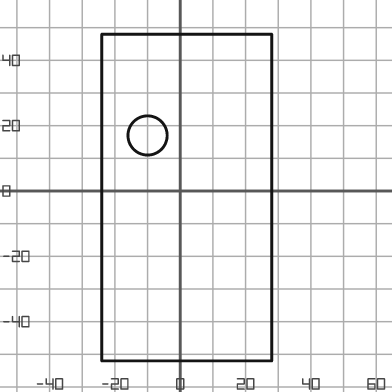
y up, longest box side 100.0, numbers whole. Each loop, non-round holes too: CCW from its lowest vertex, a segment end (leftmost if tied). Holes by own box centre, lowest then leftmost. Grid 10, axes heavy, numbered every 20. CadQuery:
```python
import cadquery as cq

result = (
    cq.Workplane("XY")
    .moveTo(-24.0, -52.0)
    .lineTo(28.0, -52.0)
    .lineTo(28.0, 48.0)
    .lineTo(-24.0, 48.0)
    .close()
    .moveTo(-10.0, 17.0)
    .circle(6.0)
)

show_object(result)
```